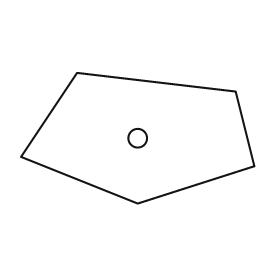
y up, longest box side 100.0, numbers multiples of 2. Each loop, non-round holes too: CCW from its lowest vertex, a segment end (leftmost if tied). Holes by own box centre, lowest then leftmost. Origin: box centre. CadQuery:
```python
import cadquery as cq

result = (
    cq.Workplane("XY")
    .moveTo(0.0, -28.0)
    .lineTo(50.0, -12.0)
    .lineTo(42.0, 20.0)
    .lineTo(-26.0, 28.0)
    .lineTo(-50.0, -8.0)
    .close()
    .moveTo(0.0, 0.0)
    .circle(4.0)
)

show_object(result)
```